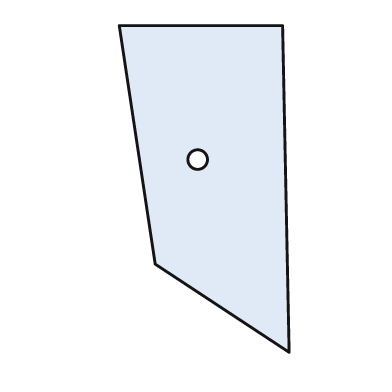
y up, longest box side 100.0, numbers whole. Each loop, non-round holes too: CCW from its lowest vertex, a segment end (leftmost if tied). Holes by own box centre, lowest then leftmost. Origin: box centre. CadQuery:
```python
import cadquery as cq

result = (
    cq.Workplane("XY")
    .moveTo(26.0, -50.0)
    .lineTo(24.0, 50.0)
    .lineTo(-26.0, 50.0)
    .lineTo(-15.0, -23.0)
    .close()
    .moveTo(-2.0, 9.0)
    .circle(3.0)
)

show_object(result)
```